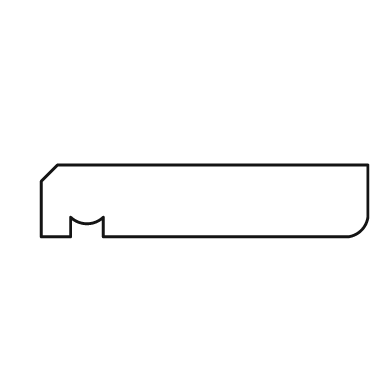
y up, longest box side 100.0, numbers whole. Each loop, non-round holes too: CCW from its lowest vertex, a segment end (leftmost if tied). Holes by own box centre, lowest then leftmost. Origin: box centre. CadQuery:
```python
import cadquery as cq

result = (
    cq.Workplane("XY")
    .moveTo(-50.0, -11.0)
    .lineTo(-41.0, -11.0)
    .lineTo(-41.0, -5.0)
    .threePointArc((-36.0, -7.0), (-31.0, -5.0))
    .lineTo(-31.0, -11.0)
    .lineTo(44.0, -11.0)
    .threePointArc((48.0, -9.0), (50.0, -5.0))
    .lineTo(50.0, 11.0)
    .lineTo(-45.0, 11.0)
    .lineTo(-50.0, 6.0)
    .close()
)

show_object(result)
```